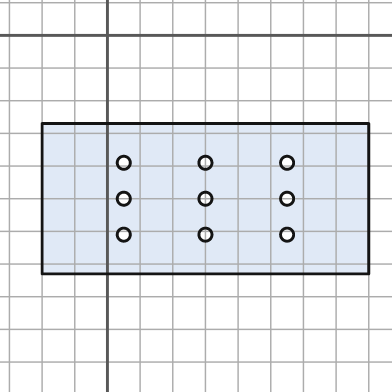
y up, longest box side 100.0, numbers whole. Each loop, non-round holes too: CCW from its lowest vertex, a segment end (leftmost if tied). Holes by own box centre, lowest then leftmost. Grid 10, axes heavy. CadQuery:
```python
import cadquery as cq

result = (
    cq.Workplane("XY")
    .moveTo(-20.0, -73.0)
    .lineTo(80.0, -73.0)
    .lineTo(80.0, -27.0)
    .lineTo(-20.0, -27.0)
    .close()
    .moveTo(5.0, -61.0)
    .circle(2.0)
    .moveTo(30.0, -61.0)
    .circle(2.0)
    .moveTo(55.0, -61.0)
    .circle(2.0)
    .moveTo(5.0, -50.0)
    .circle(2.0)
    .moveTo(30.0, -50.0)
    .circle(2.0)
    .moveTo(55.0, -50.0)
    .circle(2.0)
    .moveTo(5.0, -39.0)
    .circle(2.0)
    .moveTo(30.0, -39.0)
    .circle(2.0)
    .moveTo(55.0, -39.0)
    .circle(2.0)
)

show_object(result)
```